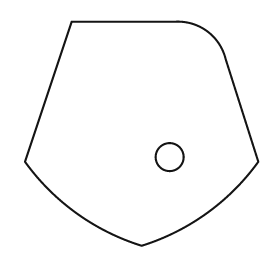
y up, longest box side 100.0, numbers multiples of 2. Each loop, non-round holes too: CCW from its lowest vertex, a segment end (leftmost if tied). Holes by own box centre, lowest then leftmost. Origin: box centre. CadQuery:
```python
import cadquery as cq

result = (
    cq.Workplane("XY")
    .moveTo(0.0, -48.0)
    .threePointArc((28.0, -34.0), (50.0, -12.0))
    .lineTo(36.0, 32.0)
    .threePointArc((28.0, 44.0), (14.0, 48.0))
    .lineTo(-30.0, 48.0)
    .lineTo(-50.0, -12.0)
    .threePointArc((-28.0, -34.0), (0.0, -48.0))
    .close()
    .moveTo(12.0, -10.0)
    .circle(6.0)
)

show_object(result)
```